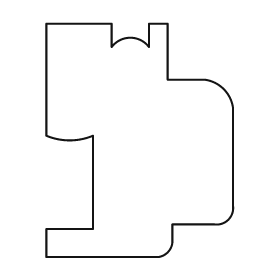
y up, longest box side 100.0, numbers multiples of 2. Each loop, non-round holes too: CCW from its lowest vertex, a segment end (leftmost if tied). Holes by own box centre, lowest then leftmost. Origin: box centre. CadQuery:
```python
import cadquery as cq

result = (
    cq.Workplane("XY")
    .moveTo(-40.0, -50.0)
    .lineTo(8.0, -50.0)
    .threePointArc((12.0, -48.0), (14.0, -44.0))
    .lineTo(14.0, -36.0)
    .lineTo(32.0, -36.0)
    .threePointArc((38.0, -34.0), (40.0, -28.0))
    .lineTo(40.0, 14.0)
    .threePointArc((36.0, 22.0), (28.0, 26.0))
    .lineTo(12.0, 26.0)
    .lineTo(12.0, 50.0)
    .lineTo(4.0, 50.0)
    .lineTo(4.0, 40.0)
    .threePointArc((-4.0, 44.0), (-12.0, 40.0))
    .lineTo(-12.0, 50.0)
    .lineTo(-40.0, 50.0)
    .lineTo(-40.0, 2.0)
    .threePointArc((-30.0, 0.0), (-20.0, 2.0))
    .lineTo(-20.0, -38.0)
    .lineTo(-40.0, -38.0)
    .close()
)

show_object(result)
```